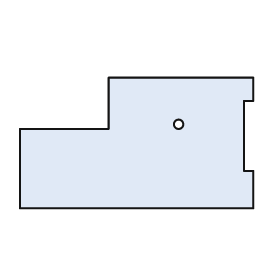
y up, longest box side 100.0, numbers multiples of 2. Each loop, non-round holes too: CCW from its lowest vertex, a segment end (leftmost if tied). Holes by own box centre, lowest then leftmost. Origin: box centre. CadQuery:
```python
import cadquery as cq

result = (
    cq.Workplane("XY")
    .moveTo(-50.0, -28.0)
    .lineTo(50.0, -28.0)
    .lineTo(50.0, -12.0)
    .lineTo(46.0, -12.0)
    .lineTo(46.0, 18.0)
    .lineTo(50.0, 18.0)
    .lineTo(50.0, 28.0)
    .lineTo(-12.0, 28.0)
    .lineTo(-12.0, 6.0)
    .lineTo(-50.0, 6.0)
    .close()
    .moveTo(18.0, 8.0)
    .circle(2.0)
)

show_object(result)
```